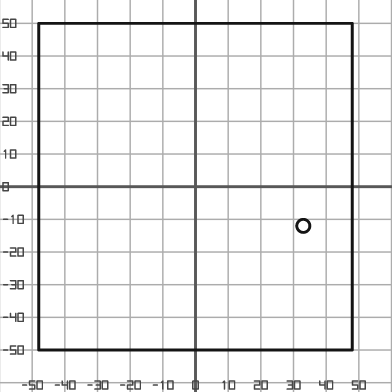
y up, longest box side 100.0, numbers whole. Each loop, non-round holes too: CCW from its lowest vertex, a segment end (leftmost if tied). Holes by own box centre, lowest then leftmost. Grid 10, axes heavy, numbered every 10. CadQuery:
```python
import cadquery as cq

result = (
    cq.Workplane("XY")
    .moveTo(-48.0, -50.0)
    .lineTo(48.0, -50.0)
    .lineTo(48.0, 50.0)
    .lineTo(-48.0, 50.0)
    .close()
    .moveTo(33.0, -12.0)
    .circle(2.0)
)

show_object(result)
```